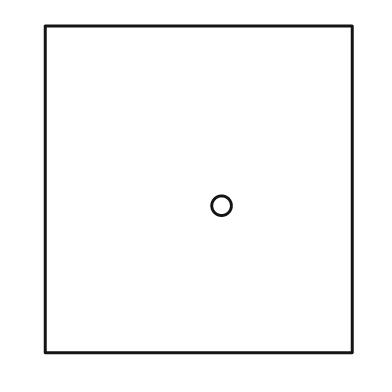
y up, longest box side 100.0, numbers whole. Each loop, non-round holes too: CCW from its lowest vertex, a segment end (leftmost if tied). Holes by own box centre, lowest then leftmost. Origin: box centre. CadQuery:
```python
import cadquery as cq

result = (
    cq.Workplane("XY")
    .moveTo(-47.0, -50.0)
    .lineTo(47.0, -50.0)
    .lineTo(47.0, 50.0)
    .lineTo(-47.0, 50.0)
    .close()
    .moveTo(7.0, -5.0)
    .circle(3.0)
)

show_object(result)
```